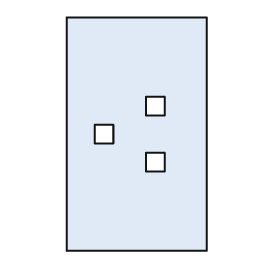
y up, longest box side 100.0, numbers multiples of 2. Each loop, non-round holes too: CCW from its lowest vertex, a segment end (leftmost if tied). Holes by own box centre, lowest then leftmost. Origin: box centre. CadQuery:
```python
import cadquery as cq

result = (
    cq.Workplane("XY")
    .moveTo(-30.0, -50.0)
    .lineTo(30.0, -50.0)
    .lineTo(30.0, 50.0)
    .lineTo(-30.0, 50.0)
    .close()
    .moveTo(4.0, -16.0)
    .lineTo(12.0, -16.0)
    .lineTo(12.0, -8.0)
    .lineTo(4.0, -8.0)
    .close()
    .moveTo(-18.0, -4.0)
    .lineTo(-10.0, -4.0)
    .lineTo(-10.0, 4.0)
    .lineTo(-18.0, 4.0)
    .close()
    .moveTo(4.0, 8.0)
    .lineTo(12.0, 8.0)
    .lineTo(12.0, 16.0)
    .lineTo(4.0, 16.0)
    .close()
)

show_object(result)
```